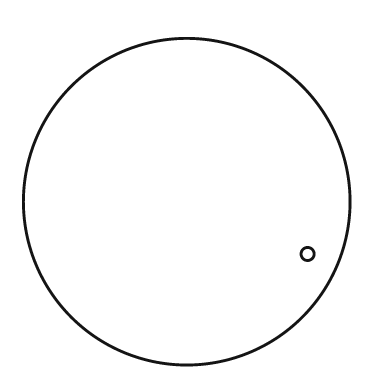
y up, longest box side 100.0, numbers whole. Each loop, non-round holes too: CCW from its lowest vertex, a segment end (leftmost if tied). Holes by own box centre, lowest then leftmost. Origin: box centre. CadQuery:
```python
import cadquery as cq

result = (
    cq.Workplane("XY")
    .moveTo(0.0, 0.0)
    .circle(50.0)
    .moveTo(37.0, -16.0)
    .circle(2.0)
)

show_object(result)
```